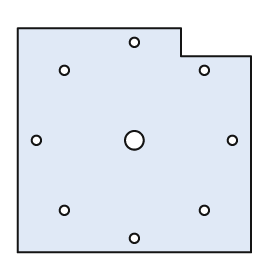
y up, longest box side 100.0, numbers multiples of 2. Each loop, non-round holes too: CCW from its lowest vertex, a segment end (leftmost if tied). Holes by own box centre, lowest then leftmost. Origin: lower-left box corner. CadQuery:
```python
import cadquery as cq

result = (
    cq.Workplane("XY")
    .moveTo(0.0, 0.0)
    .lineTo(100.0, 0.0)
    .lineTo(100.0, 84.0)
    .lineTo(70.0, 84.0)
    .lineTo(70.0, 96.0)
    .lineTo(0.0, 96.0)
    .close()
    .moveTo(50.0, 6.0)
    .circle(2.0)
    .moveTo(20.0, 18.0)
    .circle(2.0)
    .moveTo(80.0, 18.0)
    .circle(2.0)
    .moveTo(8.0, 48.0)
    .circle(2.0)
    .moveTo(50.0, 48.0)
    .circle(4.0)
    .moveTo(92.0, 48.0)
    .circle(2.0)
    .moveTo(20.0, 78.0)
    .circle(2.0)
    .moveTo(80.0, 78.0)
    .circle(2.0)
    .moveTo(50.0, 90.0)
    .circle(2.0)
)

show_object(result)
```